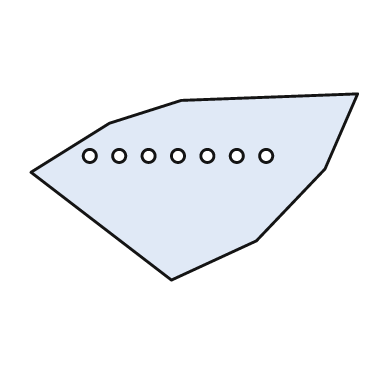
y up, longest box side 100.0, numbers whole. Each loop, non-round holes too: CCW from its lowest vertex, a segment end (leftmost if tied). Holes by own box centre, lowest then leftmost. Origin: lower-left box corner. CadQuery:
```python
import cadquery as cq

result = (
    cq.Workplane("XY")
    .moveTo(43.0, 0.0)
    .lineTo(69.0, 12.0)
    .lineTo(90.0, 34.0)
    .lineTo(100.0, 57.0)
    .lineTo(46.0, 55.0)
    .lineTo(24.0, 48.0)
    .lineTo(0.0, 33.0)
    .close()
    .moveTo(18.0, 38.0)
    .circle(2.0)
    .moveTo(27.0, 38.0)
    .circle(2.0)
    .moveTo(36.0, 38.0)
    .circle(2.0)
    .moveTo(45.0, 38.0)
    .circle(2.0)
    .moveTo(54.0, 38.0)
    .circle(2.0)
    .moveTo(63.0, 38.0)
    .circle(2.0)
    .moveTo(72.0, 38.0)
    .circle(2.0)
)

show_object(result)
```